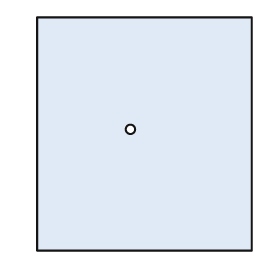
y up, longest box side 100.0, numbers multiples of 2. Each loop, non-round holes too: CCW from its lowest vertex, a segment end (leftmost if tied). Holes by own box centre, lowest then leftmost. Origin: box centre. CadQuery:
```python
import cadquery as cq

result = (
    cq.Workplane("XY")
    .moveTo(-46.0, -50.0)
    .lineTo(46.0, -50.0)
    .lineTo(46.0, 50.0)
    .lineTo(-46.0, 50.0)
    .close()
    .moveTo(-6.0, 2.0)
    .circle(2.0)
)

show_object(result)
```